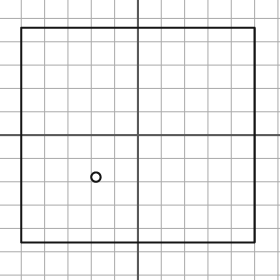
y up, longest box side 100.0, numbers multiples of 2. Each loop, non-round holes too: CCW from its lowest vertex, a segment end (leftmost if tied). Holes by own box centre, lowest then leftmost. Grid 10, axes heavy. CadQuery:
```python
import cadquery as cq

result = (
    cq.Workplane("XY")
    .moveTo(-50.0, -46.0)
    .lineTo(50.0, -46.0)
    .lineTo(50.0, 46.0)
    .lineTo(-50.0, 46.0)
    .close()
    .moveTo(-18.0, -18.0)
    .circle(2.0)
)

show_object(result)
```